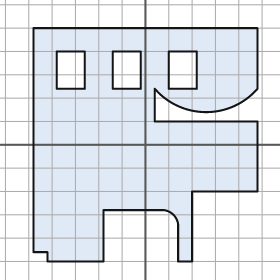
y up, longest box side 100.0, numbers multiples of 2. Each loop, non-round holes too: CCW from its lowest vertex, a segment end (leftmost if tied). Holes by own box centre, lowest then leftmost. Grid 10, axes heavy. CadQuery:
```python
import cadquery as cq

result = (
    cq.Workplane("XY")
    .moveTo(-42.0, -50.0)
    .lineTo(-18.0, -50.0)
    .lineTo(-18.0, -28.0)
    .lineTo(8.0, -28.0)
    .threePointArc((12.0, -30.0), (14.0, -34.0))
    .lineTo(14.0, -50.0)
    .lineTo(20.0, -50.0)
    .lineTo(20.0, -20.0)
    .lineTo(48.0, -20.0)
    .lineTo(48.0, 10.0)
    .lineTo(4.0, 10.0)
    .lineTo(4.0, 24.0)
    .threePointArc((26.0, 14.0), (48.0, 24.0))
    .lineTo(48.0, 50.0)
    .lineTo(-48.0, 50.0)
    .lineTo(-48.0, -46.0)
    .lineTo(-42.0, -46.0)
    .close()
    .moveTo(-38.0, 24.0)
    .lineTo(-26.0, 24.0)
    .lineTo(-26.0, 40.0)
    .lineTo(-38.0, 40.0)
    .close()
    .moveTo(-14.0, 24.0)
    .lineTo(-2.0, 24.0)
    .lineTo(-2.0, 40.0)
    .lineTo(-14.0, 40.0)
    .close()
    .moveTo(10.0, 24.0)
    .lineTo(22.0, 24.0)
    .lineTo(22.0, 40.0)
    .lineTo(10.0, 40.0)
    .close()
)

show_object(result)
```